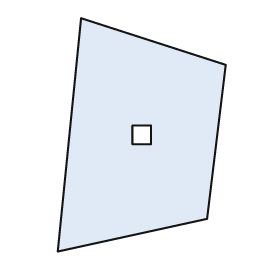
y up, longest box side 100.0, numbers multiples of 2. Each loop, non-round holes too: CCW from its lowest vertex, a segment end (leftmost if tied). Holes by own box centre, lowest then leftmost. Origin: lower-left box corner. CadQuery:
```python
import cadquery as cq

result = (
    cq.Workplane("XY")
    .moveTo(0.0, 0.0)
    .lineTo(64.0, 14.0)
    .lineTo(72.0, 80.0)
    .lineTo(10.0, 100.0)
    .close()
    .moveTo(32.0, 46.0)
    .lineTo(40.0, 46.0)
    .lineTo(40.0, 54.0)
    .lineTo(32.0, 54.0)
    .close()
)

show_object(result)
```